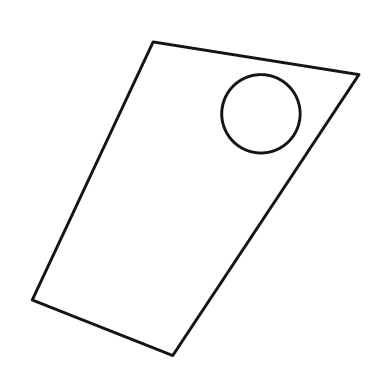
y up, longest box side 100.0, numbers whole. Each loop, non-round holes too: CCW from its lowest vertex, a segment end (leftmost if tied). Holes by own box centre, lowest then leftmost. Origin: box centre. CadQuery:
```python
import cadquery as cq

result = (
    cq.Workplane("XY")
    .moveTo(-7.0, -48.0)
    .lineTo(50.0, 38.0)
    .lineTo(-13.0, 48.0)
    .lineTo(-50.0, -31.0)
    .close()
    .moveTo(20.0, 26.0)
    .circle(12.0)
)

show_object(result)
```